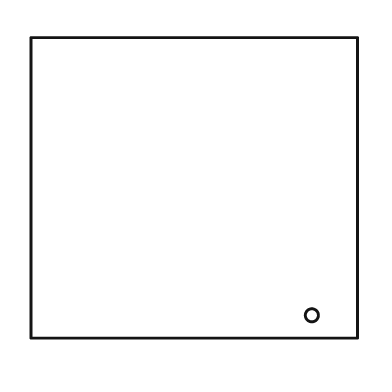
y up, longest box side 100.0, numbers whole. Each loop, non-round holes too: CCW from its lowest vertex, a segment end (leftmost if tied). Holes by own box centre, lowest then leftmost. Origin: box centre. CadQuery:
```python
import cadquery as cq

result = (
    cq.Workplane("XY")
    .moveTo(-50.0, -46.0)
    .lineTo(50.0, -46.0)
    .lineTo(50.0, 46.0)
    .lineTo(-50.0, 46.0)
    .close()
    .moveTo(36.0, -39.0)
    .circle(2.0)
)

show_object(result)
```